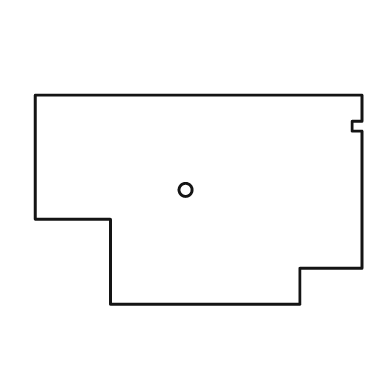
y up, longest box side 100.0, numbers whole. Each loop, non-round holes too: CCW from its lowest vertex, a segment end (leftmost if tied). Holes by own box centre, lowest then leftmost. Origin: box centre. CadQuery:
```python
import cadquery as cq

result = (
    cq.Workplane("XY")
    .moveTo(-27.0, -32.0)
    .lineTo(31.0, -32.0)
    .lineTo(31.0, -21.0)
    .lineTo(50.0, -21.0)
    .lineTo(50.0, 21.0)
    .lineTo(47.0, 21.0)
    .lineTo(47.0, 24.0)
    .lineTo(50.0, 24.0)
    .lineTo(50.0, 32.0)
    .lineTo(-50.0, 32.0)
    .lineTo(-50.0, -6.0)
    .lineTo(-27.0, -6.0)
    .close()
    .moveTo(-4.0, 3.0)
    .circle(2.0)
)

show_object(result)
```